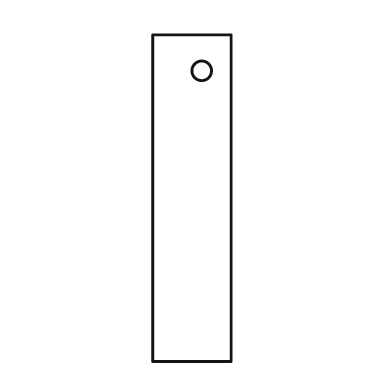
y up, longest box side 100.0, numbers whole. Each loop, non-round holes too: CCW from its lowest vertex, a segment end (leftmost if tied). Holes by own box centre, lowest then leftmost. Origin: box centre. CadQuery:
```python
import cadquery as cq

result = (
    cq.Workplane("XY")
    .moveTo(-12.0, -50.0)
    .lineTo(12.0, -50.0)
    .lineTo(12.0, 50.0)
    .lineTo(-12.0, 50.0)
    .close()
    .moveTo(3.0, 39.0)
    .circle(3.0)
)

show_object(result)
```